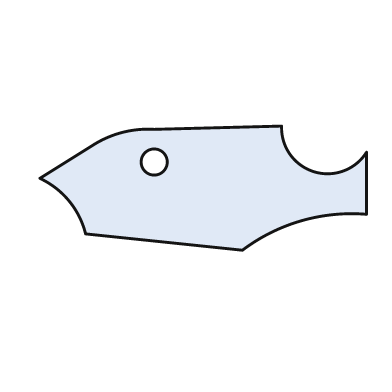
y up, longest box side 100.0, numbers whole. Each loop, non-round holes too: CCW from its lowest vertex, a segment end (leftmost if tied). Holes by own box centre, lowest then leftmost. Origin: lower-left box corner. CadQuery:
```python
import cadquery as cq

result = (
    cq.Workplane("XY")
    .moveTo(62.0, 0.0)
    .threePointArc((80.0, 9.0), (100.0, 11.0))
    .lineTo(100.0, 30.0)
    .threePointArc((84.0, 24.0), (74.0, 38.0))
    .lineTo(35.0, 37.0)
    .threePointArc((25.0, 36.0), (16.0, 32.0))
    .lineTo(0.0, 22.0)
    .threePointArc((9.0, 15.0), (14.0, 5.0))
    .close()
    .moveTo(35.0, 27.0)
    .circle(4.0)
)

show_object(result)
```